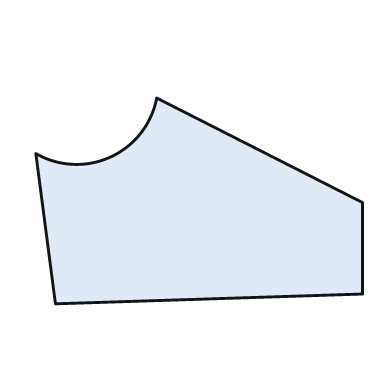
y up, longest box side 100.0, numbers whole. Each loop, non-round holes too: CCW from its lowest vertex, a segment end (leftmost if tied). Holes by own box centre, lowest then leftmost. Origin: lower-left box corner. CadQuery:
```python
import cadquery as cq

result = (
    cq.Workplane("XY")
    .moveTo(6.0, 0.0)
    .lineTo(100.0, 3.0)
    .lineTo(100.0, 31.0)
    .lineTo(37.0, 63.0)
    .threePointArc((23.0, 45.0), (0.0, 46.0))
    .close()
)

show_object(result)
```